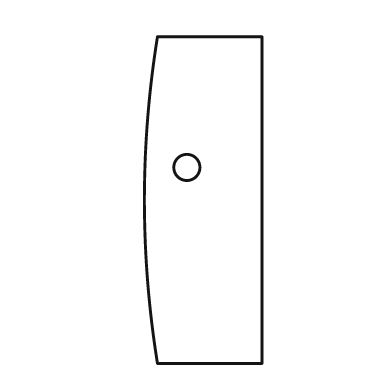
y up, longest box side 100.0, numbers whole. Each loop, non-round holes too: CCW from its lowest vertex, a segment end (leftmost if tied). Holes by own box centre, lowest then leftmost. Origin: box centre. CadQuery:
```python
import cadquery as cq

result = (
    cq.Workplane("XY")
    .moveTo(-14.0, -50.0)
    .lineTo(18.0, -50.0)
    .lineTo(18.0, 50.0)
    .lineTo(-14.0, 50.0)
    .threePointArc((-18.0, 0.0), (-14.0, -50.0))
    .close()
    .moveTo(-5.0, 10.0)
    .circle(4.0)
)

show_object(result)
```